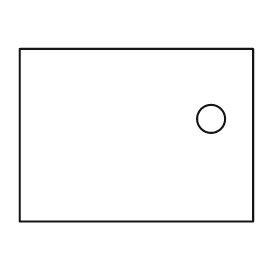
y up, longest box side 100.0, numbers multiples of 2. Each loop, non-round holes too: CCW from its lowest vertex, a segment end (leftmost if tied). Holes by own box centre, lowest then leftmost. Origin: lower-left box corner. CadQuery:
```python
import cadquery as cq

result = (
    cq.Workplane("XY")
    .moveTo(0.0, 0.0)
    .lineTo(100.0, 0.0)
    .lineTo(100.0, 74.0)
    .lineTo(0.0, 74.0)
    .close()
    .moveTo(82.0, 44.0)
    .circle(6.0)
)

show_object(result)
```